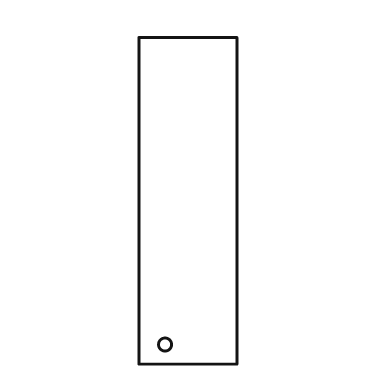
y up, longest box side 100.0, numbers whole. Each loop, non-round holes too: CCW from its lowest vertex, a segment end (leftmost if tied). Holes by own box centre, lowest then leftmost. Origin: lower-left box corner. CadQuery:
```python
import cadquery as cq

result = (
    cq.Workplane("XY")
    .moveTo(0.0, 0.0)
    .lineTo(30.0, 0.0)
    .lineTo(30.0, 100.0)
    .lineTo(0.0, 100.0)
    .close()
    .moveTo(8.0, 6.0)
    .circle(2.0)
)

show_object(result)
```